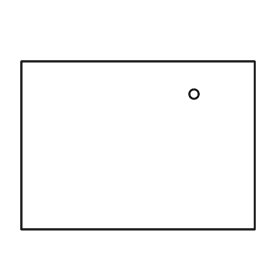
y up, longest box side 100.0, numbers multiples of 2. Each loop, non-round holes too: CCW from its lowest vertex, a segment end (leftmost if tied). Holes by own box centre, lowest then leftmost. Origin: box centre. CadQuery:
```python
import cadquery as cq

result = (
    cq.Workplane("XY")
    .moveTo(-50.0, -36.0)
    .lineTo(50.0, -36.0)
    .lineTo(50.0, 36.0)
    .lineTo(-50.0, 36.0)
    .close()
    .moveTo(24.0, 22.0)
    .circle(2.0)
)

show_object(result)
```